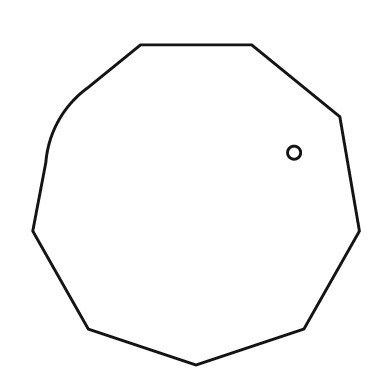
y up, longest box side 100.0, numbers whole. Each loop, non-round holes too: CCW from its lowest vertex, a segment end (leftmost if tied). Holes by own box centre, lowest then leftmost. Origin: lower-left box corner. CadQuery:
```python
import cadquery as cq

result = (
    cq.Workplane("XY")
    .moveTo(50.0, 0.0)
    .lineTo(83.0, 11.0)
    .lineTo(100.0, 41.0)
    .lineTo(94.0, 76.0)
    .lineTo(67.0, 98.0)
    .lineTo(33.0, 98.0)
    .lineTo(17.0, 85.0)
    .threePointArc((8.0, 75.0), (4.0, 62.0))
    .lineTo(0.0, 41.0)
    .lineTo(17.0, 11.0)
    .close()
    .moveTo(80.0, 65.0)
    .circle(2.0)
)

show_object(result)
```